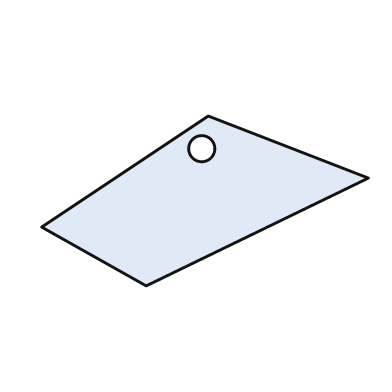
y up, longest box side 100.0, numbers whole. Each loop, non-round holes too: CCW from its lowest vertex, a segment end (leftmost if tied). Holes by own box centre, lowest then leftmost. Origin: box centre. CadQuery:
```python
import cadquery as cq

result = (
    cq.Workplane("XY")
    .moveTo(-18.0, -26.0)
    .lineTo(50.0, 7.0)
    .lineTo(1.0, 26.0)
    .lineTo(-50.0, -8.0)
    .close()
    .moveTo(-1.0, 16.0)
    .circle(4.0)
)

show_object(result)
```